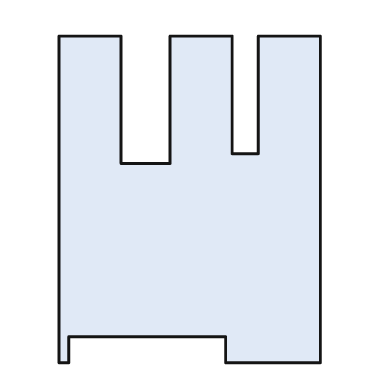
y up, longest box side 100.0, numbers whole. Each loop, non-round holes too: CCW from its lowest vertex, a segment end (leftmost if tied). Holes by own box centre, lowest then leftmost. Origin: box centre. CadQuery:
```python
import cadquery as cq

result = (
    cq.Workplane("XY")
    .moveTo(-40.0, -50.0)
    .lineTo(-37.0, -50.0)
    .lineTo(-37.0, -42.0)
    .lineTo(11.0, -42.0)
    .lineTo(11.0, -50.0)
    .lineTo(40.0, -50.0)
    .lineTo(40.0, 50.0)
    .lineTo(21.0, 50.0)
    .lineTo(21.0, 14.0)
    .lineTo(13.0, 14.0)
    .lineTo(13.0, 50.0)
    .lineTo(-6.0, 50.0)
    .lineTo(-6.0, 11.0)
    .lineTo(-21.0, 11.0)
    .lineTo(-21.0, 50.0)
    .lineTo(-40.0, 50.0)
    .close()
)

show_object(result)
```